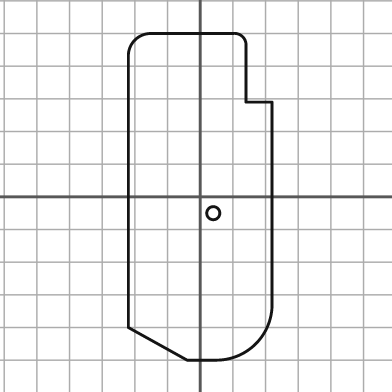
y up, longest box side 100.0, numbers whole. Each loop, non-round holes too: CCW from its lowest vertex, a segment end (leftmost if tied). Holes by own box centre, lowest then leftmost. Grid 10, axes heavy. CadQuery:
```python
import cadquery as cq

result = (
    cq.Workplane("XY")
    .moveTo(-4.0, -50.0)
    .lineTo(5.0, -50.0)
    .threePointArc((17.0, -45.0), (22.0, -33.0))
    .lineTo(22.0, 29.0)
    .lineTo(14.0, 29.0)
    .lineTo(14.0, 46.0)
    .threePointArc((13.0, 49.0), (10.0, 50.0))
    .lineTo(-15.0, 50.0)
    .threePointArc((-20.0, 48.0), (-22.0, 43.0))
    .lineTo(-22.0, -40.0)
    .close()
    .moveTo(4.0, -5.0)
    .circle(2.0)
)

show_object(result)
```